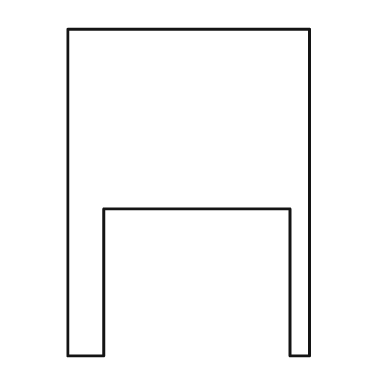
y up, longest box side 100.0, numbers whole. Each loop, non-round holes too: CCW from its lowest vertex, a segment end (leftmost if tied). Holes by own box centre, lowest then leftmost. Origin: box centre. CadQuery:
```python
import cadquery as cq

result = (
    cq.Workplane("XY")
    .moveTo(-37.0, -50.0)
    .lineTo(-26.0, -50.0)
    .lineTo(-26.0, -5.0)
    .lineTo(31.0, -5.0)
    .lineTo(31.0, -50.0)
    .lineTo(37.0, -50.0)
    .lineTo(37.0, 50.0)
    .lineTo(-37.0, 50.0)
    .close()
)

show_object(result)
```